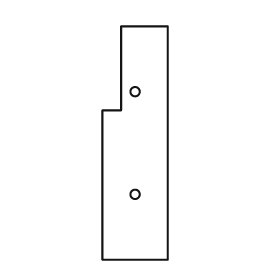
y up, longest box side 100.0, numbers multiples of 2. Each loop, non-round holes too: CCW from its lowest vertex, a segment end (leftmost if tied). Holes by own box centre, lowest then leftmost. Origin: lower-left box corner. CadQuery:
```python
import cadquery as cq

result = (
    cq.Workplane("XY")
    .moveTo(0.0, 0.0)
    .lineTo(28.0, 0.0)
    .lineTo(28.0, 100.0)
    .lineTo(8.0, 100.0)
    .lineTo(8.0, 64.0)
    .lineTo(0.0, 64.0)
    .close()
    .moveTo(14.0, 28.0)
    .circle(2.0)
    .moveTo(14.0, 72.0)
    .circle(2.0)
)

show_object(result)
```